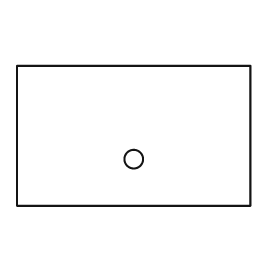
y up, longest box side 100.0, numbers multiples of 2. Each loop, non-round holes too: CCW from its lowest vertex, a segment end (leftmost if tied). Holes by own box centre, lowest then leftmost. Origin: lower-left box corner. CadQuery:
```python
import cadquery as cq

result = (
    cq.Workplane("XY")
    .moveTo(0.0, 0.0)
    .lineTo(100.0, 0.0)
    .lineTo(100.0, 60.0)
    .lineTo(0.0, 60.0)
    .close()
    .moveTo(50.0, 20.0)
    .circle(4.0)
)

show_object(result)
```